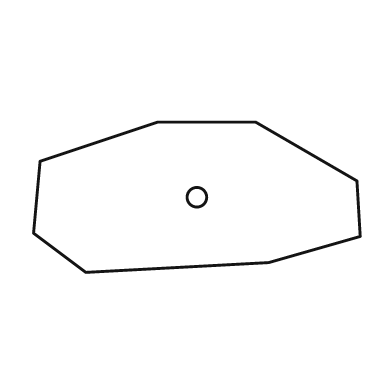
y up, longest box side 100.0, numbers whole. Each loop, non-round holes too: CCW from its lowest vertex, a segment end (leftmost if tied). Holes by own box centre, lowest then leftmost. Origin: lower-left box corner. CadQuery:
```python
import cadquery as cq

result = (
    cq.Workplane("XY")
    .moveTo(16.0, 0.0)
    .lineTo(72.0, 3.0)
    .lineTo(100.0, 11.0)
    .lineTo(99.0, 28.0)
    .lineTo(68.0, 46.0)
    .lineTo(38.0, 46.0)
    .lineTo(2.0, 34.0)
    .lineTo(0.0, 12.0)
    .close()
    .moveTo(50.0, 23.0)
    .circle(3.0)
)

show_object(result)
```